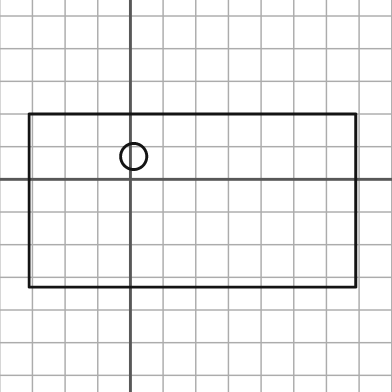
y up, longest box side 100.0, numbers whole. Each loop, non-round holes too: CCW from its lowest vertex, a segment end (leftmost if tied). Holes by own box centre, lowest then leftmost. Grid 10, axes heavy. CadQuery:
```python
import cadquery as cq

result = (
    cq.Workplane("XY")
    .moveTo(-31.0, -33.0)
    .lineTo(69.0, -33.0)
    .lineTo(69.0, 20.0)
    .lineTo(-31.0, 20.0)
    .close()
    .moveTo(1.0, 7.0)
    .circle(4.0)
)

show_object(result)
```